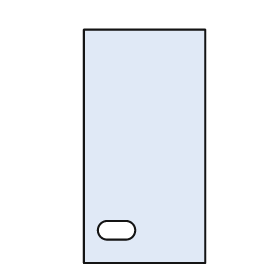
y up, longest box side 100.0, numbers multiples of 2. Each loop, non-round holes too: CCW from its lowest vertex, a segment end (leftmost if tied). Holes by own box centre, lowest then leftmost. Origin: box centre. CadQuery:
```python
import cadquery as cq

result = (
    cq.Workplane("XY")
    .moveTo(-26.0, -50.0)
    .lineTo(26.0, -50.0)
    .lineTo(26.0, 50.0)
    .lineTo(-26.0, 50.0)
    .close()
    .moveTo(-16.0, -40.0)
    .lineTo(-8.0, -40.0)
    .threePointArc((-4.0, -36.0), (-8.0, -32.0))
    .lineTo(-16.0, -32.0)
    .threePointArc((-20.0, -36.0), (-16.0, -40.0))
    .close()
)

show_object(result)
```